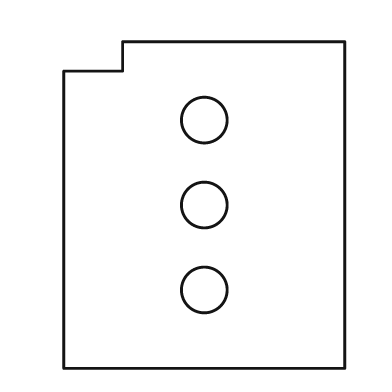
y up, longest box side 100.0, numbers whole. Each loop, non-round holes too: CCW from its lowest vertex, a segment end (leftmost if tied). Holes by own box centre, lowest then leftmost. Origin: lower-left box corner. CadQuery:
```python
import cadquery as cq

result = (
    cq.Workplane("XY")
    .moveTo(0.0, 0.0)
    .lineTo(86.0, 0.0)
    .lineTo(86.0, 100.0)
    .lineTo(18.0, 100.0)
    .lineTo(18.0, 91.0)
    .lineTo(0.0, 91.0)
    .close()
    .moveTo(43.0, 24.0)
    .circle(7.0)
    .moveTo(43.0, 50.0)
    .circle(7.0)
    .moveTo(43.0, 76.0)
    .circle(7.0)
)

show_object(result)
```